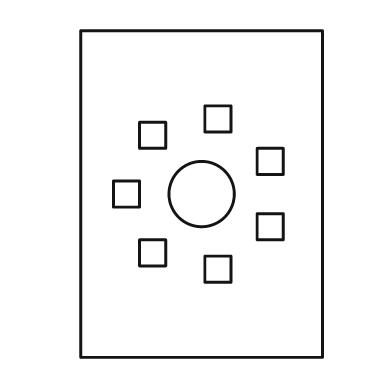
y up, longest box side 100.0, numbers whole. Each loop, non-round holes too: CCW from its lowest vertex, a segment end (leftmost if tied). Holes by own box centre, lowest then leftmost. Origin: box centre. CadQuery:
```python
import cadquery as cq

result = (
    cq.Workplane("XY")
    .moveTo(-37.0, -50.0)
    .lineTo(37.0, -50.0)
    .lineTo(37.0, 50.0)
    .lineTo(-37.0, 50.0)
    .close()
    .moveTo(1.0, -27.0)
    .lineTo(9.0, -27.0)
    .lineTo(9.0, -19.0)
    .lineTo(1.0, -19.0)
    .close()
    .moveTo(-19.0, -22.0)
    .lineTo(-11.0, -22.0)
    .lineTo(-11.0, -14.0)
    .lineTo(-19.0, -14.0)
    .close()
    .moveTo(17.0, -14.0)
    .lineTo(25.0, -14.0)
    .lineTo(25.0, -6.0)
    .lineTo(17.0, -6.0)
    .close()
    .moveTo(-27.0, -4.0)
    .lineTo(-19.0, -4.0)
    .lineTo(-19.0, 4.0)
    .lineTo(-27.0, 4.0)
    .close()
    .moveTo(0.0, 0.0)
    .circle(10.0)
    .moveTo(17.0, 6.0)
    .lineTo(25.0, 6.0)
    .lineTo(25.0, 14.0)
    .lineTo(17.0, 14.0)
    .close()
    .moveTo(-19.0, 14.0)
    .lineTo(-11.0, 14.0)
    .lineTo(-11.0, 22.0)
    .lineTo(-19.0, 22.0)
    .close()
    .moveTo(1.0, 19.0)
    .lineTo(9.0, 19.0)
    .lineTo(9.0, 27.0)
    .lineTo(1.0, 27.0)
    .close()
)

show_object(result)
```